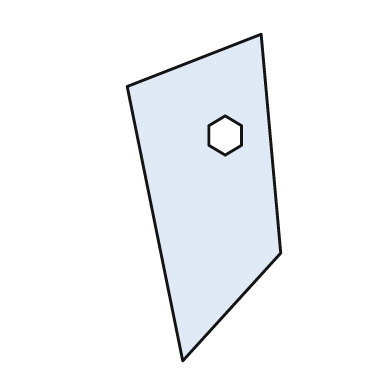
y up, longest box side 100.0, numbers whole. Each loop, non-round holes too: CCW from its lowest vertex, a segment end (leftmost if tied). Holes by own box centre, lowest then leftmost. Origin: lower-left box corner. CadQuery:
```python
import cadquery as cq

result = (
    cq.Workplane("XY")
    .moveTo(17.0, 0.0)
    .lineTo(47.0, 33.0)
    .lineTo(41.0, 100.0)
    .lineTo(0.0, 84.0)
    .close()
    .moveTo(30.0, 63.0)
    .lineTo(35.0, 66.0)
    .lineTo(35.0, 72.0)
    .lineTo(30.0, 75.0)
    .lineTo(25.0, 72.0)
    .lineTo(25.0, 66.0)
    .close()
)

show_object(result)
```